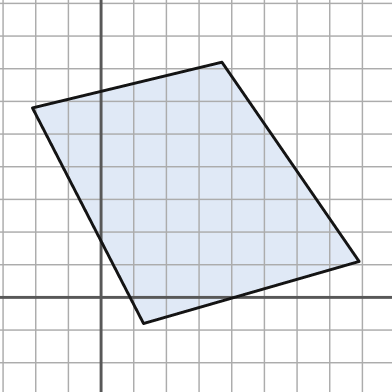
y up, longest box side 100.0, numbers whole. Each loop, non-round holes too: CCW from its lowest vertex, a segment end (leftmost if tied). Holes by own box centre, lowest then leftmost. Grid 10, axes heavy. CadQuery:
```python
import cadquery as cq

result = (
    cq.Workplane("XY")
    .moveTo(13.0, -8.0)
    .lineTo(79.0, 11.0)
    .lineTo(37.0, 72.0)
    .lineTo(-21.0, 58.0)
    .close()
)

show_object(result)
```